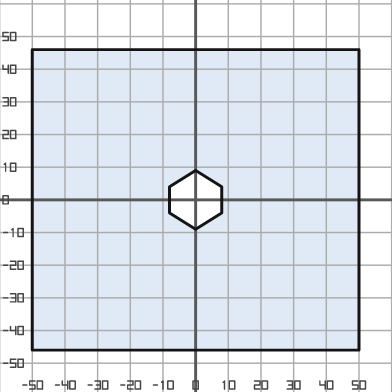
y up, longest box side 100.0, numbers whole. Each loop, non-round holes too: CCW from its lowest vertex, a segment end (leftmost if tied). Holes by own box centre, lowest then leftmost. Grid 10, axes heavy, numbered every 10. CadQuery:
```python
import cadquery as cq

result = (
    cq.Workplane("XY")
    .moveTo(-50.0, -46.0)
    .lineTo(50.0, -46.0)
    .lineTo(50.0, 46.0)
    .lineTo(-50.0, 46.0)
    .close()
    .moveTo(0.0, -9.0)
    .lineTo(8.0, -4.0)
    .lineTo(8.0, 4.0)
    .lineTo(0.0, 9.0)
    .lineTo(-8.0, 4.0)
    .lineTo(-8.0, -4.0)
    .close()
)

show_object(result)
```